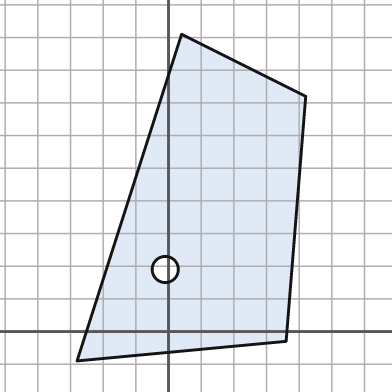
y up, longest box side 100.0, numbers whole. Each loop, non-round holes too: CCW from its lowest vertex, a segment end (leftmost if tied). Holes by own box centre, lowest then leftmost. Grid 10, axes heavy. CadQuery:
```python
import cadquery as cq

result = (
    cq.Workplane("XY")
    .moveTo(-28.0, -9.0)
    .lineTo(36.0, -3.0)
    .lineTo(42.0, 72.0)
    .lineTo(4.0, 91.0)
    .close()
    .moveTo(-1.0, 19.0)
    .circle(4.0)
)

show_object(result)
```